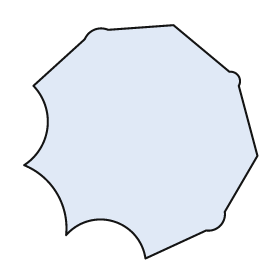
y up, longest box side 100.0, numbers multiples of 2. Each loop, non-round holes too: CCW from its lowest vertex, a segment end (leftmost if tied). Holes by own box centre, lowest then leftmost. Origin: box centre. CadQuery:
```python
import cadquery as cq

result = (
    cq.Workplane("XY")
    .moveTo(2.0, -50.0)
    .lineTo(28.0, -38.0)
    .threePointArc((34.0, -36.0), (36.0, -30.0))
    .lineTo(50.0, -6.0)
    .lineTo(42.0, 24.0)
    .threePointArc((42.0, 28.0), (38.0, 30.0))
    .lineTo(14.0, 50.0)
    .lineTo(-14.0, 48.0)
    .threePointArc((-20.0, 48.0), (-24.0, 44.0))
    .lineTo(-46.0, 24.0)
    .threePointArc((-40.0, 6.0), (-50.0, -10.0))
    .threePointArc((-36.0, -22.0), (-32.0, -40.0))
    .threePointArc((-12.0, -34.0), (2.0, -50.0))
    .close()
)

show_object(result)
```